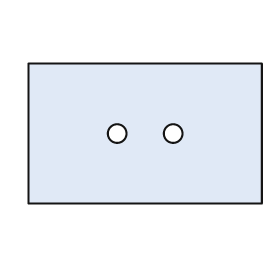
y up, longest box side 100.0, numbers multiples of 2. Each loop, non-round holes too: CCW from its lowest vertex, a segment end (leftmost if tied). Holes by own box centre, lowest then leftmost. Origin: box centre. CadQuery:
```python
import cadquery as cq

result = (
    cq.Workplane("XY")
    .moveTo(-50.0, -30.0)
    .lineTo(50.0, -30.0)
    .lineTo(50.0, 30.0)
    .lineTo(-50.0, 30.0)
    .close()
    .moveTo(-12.0, 0.0)
    .circle(4.0)
    .moveTo(12.0, 0.0)
    .circle(4.0)
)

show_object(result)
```